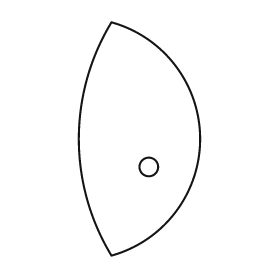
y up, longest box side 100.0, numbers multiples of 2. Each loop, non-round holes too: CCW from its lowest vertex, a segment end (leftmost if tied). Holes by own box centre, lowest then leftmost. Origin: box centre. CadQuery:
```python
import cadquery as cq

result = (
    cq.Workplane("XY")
    .moveTo(-12.0, -50.0)
    .threePointArc((26.0, 0.0), (-12.0, 50.0))
    .threePointArc((-26.0, 0.0), (-12.0, -50.0))
    .close()
    .moveTo(4.0, -12.0)
    .circle(4.0)
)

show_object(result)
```